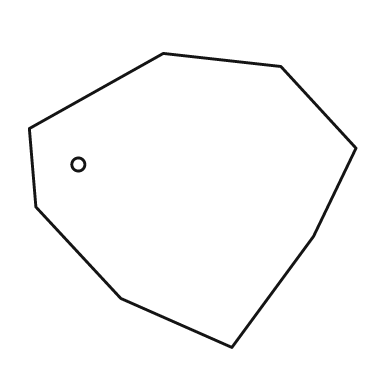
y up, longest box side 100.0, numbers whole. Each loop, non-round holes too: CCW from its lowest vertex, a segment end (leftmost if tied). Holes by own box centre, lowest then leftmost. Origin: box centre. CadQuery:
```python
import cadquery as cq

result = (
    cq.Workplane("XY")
    .moveTo(12.0, -45.0)
    .lineTo(37.0, -11.0)
    .lineTo(50.0, 16.0)
    .lineTo(27.0, 41.0)
    .lineTo(-9.0, 45.0)
    .lineTo(-50.0, 22.0)
    .lineTo(-48.0, -2.0)
    .lineTo(-22.0, -30.0)
    .close()
    .moveTo(-35.0, 11.0)
    .circle(2.0)
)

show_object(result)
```